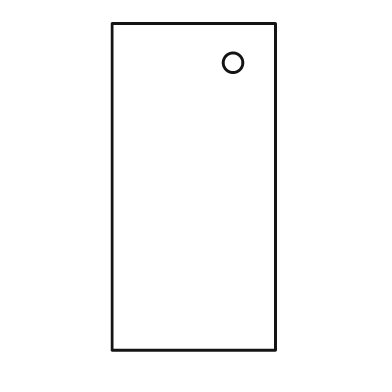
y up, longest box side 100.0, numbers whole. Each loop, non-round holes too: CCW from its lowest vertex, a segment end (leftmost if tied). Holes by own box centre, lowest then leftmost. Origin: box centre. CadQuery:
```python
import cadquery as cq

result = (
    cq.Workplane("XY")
    .moveTo(-25.0, -50.0)
    .lineTo(25.0, -50.0)
    .lineTo(25.0, 50.0)
    .lineTo(-25.0, 50.0)
    .close()
    .moveTo(12.0, 38.0)
    .circle(3.0)
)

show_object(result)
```